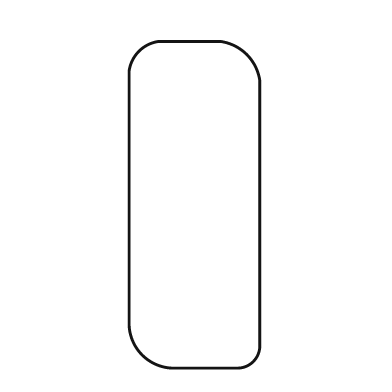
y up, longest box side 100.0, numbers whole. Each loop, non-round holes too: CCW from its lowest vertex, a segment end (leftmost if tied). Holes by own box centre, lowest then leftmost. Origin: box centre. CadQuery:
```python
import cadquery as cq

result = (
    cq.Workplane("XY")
    .moveTo(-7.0, -50.0)
    .lineTo(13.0, -50.0)
    .threePointArc((18.0, -48.0), (20.0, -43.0))
    .lineTo(20.0, 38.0)
    .threePointArc((16.0, 46.0), (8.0, 50.0))
    .lineTo(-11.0, 50.0)
    .threePointArc((-17.0, 47.0), (-20.0, 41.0))
    .lineTo(-20.0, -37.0)
    .threePointArc((-16.0, -46.0), (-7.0, -50.0))
    .close()
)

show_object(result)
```